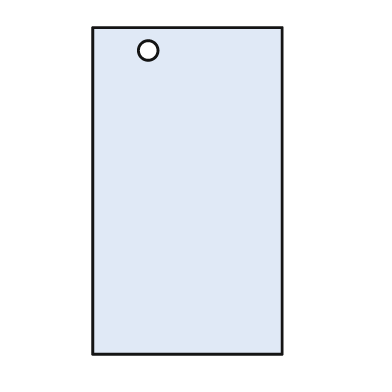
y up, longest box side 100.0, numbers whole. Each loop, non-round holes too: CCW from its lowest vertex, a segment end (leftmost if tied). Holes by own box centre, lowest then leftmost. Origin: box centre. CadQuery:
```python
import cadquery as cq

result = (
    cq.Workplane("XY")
    .moveTo(-29.0, -50.0)
    .lineTo(29.0, -50.0)
    .lineTo(29.0, 50.0)
    .lineTo(-29.0, 50.0)
    .close()
    .moveTo(-12.0, 43.0)
    .circle(3.0)
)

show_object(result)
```